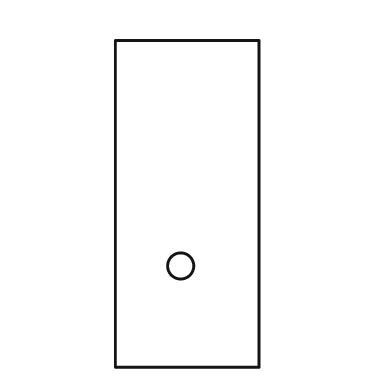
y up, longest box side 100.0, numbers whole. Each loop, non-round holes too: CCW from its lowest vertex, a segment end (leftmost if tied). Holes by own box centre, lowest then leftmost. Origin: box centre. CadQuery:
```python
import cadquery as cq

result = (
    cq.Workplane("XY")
    .moveTo(-22.0, -50.0)
    .lineTo(22.0, -50.0)
    .lineTo(22.0, 50.0)
    .lineTo(-22.0, 50.0)
    .close()
    .moveTo(-2.0, -19.0)
    .circle(4.0)
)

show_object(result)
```